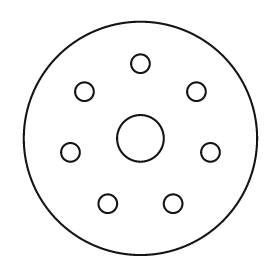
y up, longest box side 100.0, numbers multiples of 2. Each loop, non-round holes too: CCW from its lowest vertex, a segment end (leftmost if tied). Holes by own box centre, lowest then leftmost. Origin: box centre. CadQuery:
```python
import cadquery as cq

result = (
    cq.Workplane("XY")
    .moveTo(0.0, 0.0)
    .circle(50.0)
    .moveTo(-14.0, -28.0)
    .circle(4.0)
    .moveTo(14.0, -28.0)
    .circle(4.0)
    .moveTo(-30.0, -6.0)
    .circle(4.0)
    .moveTo(30.0, -6.0)
    .circle(4.0)
    .moveTo(0.0, 0.0)
    .circle(10.0)
    .moveTo(-24.0, 20.0)
    .circle(4.0)
    .moveTo(24.0, 20.0)
    .circle(4.0)
    .moveTo(0.0, 32.0)
    .circle(4.0)
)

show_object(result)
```